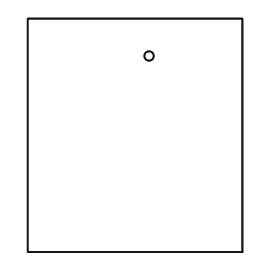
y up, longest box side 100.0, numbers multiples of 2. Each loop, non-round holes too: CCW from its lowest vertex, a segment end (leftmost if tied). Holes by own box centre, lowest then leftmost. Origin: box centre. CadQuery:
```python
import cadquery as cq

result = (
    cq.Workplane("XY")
    .moveTo(-46.0, -50.0)
    .lineTo(46.0, -50.0)
    .lineTo(46.0, 50.0)
    .lineTo(-46.0, 50.0)
    .close()
    .moveTo(6.0, 34.0)
    .circle(2.0)
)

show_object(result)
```